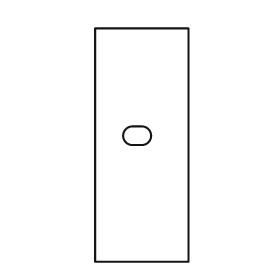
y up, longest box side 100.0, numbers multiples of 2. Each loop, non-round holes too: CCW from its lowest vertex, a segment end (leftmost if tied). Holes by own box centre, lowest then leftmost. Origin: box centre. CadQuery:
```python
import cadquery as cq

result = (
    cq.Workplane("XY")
    .moveTo(-20.0, -50.0)
    .lineTo(20.0, -50.0)
    .lineTo(20.0, 50.0)
    .lineTo(-20.0, 50.0)
    .close()
    .moveTo(-4.0, 0.0)
    .lineTo(0.0, 0.0)
    .threePointArc((4.0, 4.0), (0.0, 8.0))
    .lineTo(-4.0, 8.0)
    .threePointArc((-8.0, 4.0), (-4.0, 0.0))
    .close()
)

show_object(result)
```